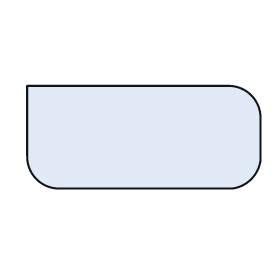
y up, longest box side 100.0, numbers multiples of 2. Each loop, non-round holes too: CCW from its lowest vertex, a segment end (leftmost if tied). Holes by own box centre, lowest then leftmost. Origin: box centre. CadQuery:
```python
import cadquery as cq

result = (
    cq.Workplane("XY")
    .moveTo(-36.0, -22.0)
    .lineTo(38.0, -22.0)
    .threePointArc((46.0, -18.0), (50.0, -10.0))
    .lineTo(50.0, 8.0)
    .threePointArc((46.0, 18.0), (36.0, 22.0))
    .lineTo(-50.0, 22.0)
    .lineTo(-50.0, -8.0)
    .threePointArc((-46.0, -18.0), (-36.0, -22.0))
    .close()
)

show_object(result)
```